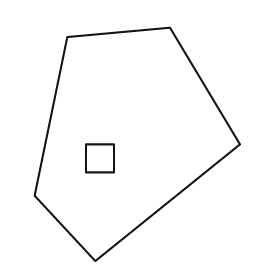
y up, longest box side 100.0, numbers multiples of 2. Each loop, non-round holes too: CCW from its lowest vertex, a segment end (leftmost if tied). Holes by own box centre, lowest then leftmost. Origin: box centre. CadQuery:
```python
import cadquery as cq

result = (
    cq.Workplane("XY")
    .moveTo(-18.0, -50.0)
    .lineTo(44.0, 0.0)
    .lineTo(14.0, 50.0)
    .lineTo(-30.0, 46.0)
    .lineTo(-44.0, -22.0)
    .close()
    .moveTo(-22.0, -12.0)
    .lineTo(-10.0, -12.0)
    .lineTo(-10.0, 0.0)
    .lineTo(-22.0, 0.0)
    .close()
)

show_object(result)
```